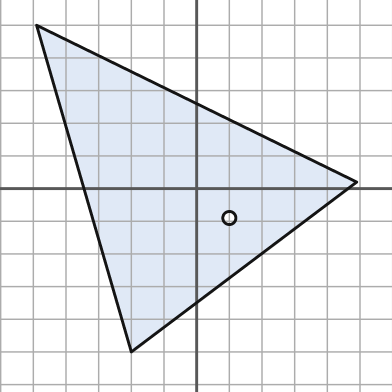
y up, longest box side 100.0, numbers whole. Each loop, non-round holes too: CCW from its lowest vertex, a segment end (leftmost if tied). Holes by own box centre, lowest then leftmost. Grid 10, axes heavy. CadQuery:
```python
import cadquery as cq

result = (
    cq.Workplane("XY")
    .moveTo(-20.0, -50.0)
    .lineTo(49.0, 2.0)
    .lineTo(-49.0, 50.0)
    .close()
    .moveTo(10.0, -9.0)
    .circle(2.0)
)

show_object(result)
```